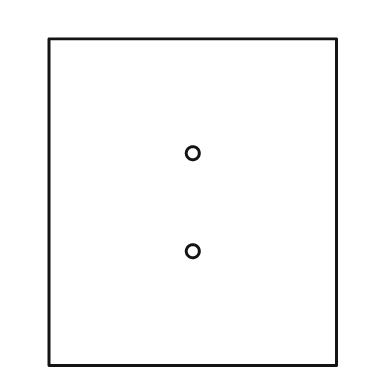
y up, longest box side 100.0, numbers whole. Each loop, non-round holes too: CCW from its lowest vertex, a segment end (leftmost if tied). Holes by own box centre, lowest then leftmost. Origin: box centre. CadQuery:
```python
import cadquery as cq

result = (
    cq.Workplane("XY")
    .moveTo(-44.0, -50.0)
    .lineTo(44.0, -50.0)
    .lineTo(44.0, 50.0)
    .lineTo(-44.0, 50.0)
    .close()
    .moveTo(0.0, -15.0)
    .circle(2.0)
    .moveTo(0.0, 15.0)
    .circle(2.0)
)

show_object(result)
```